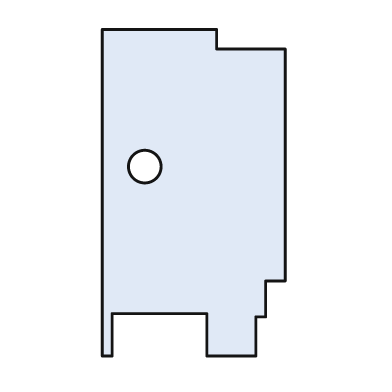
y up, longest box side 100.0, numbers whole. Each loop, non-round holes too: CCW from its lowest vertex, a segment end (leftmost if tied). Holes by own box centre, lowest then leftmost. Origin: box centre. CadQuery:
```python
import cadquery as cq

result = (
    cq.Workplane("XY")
    .moveTo(-28.0, -50.0)
    .lineTo(-25.0, -50.0)
    .lineTo(-25.0, -37.0)
    .lineTo(4.0, -37.0)
    .lineTo(4.0, -50.0)
    .lineTo(19.0, -50.0)
    .lineTo(19.0, -38.0)
    .lineTo(22.0, -38.0)
    .lineTo(22.0, -27.0)
    .lineTo(28.0, -27.0)
    .lineTo(28.0, 44.0)
    .lineTo(7.0, 44.0)
    .lineTo(7.0, 50.0)
    .lineTo(-28.0, 50.0)
    .close()
    .moveTo(-15.0, 8.0)
    .circle(5.0)
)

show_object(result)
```